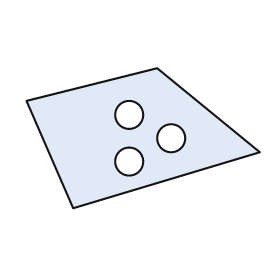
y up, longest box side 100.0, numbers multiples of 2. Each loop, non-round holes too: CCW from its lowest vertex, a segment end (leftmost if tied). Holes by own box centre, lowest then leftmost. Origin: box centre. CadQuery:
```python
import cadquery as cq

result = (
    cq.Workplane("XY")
    .moveTo(-30.0, -30.0)
    .lineTo(50.0, -6.0)
    .lineTo(6.0, 30.0)
    .lineTo(-50.0, 16.0)
    .close()
    .moveTo(-6.0, -10.0)
    .circle(6.0)
    .moveTo(12.0, 0.0)
    .circle(6.0)
    .moveTo(-6.0, 10.0)
    .circle(6.0)
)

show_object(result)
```